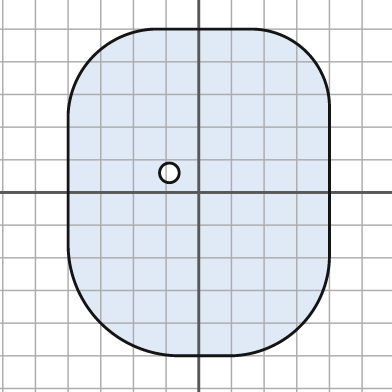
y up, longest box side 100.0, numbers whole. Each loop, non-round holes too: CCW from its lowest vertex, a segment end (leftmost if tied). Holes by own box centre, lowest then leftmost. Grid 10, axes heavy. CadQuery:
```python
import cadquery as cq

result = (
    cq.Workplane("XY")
    .moveTo(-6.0, -50.0)
    .lineTo(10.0, -50.0)
    .threePointArc((31.0, -41.0), (40.0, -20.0))
    .lineTo(40.0, 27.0)
    .threePointArc((33.0, 43.0), (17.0, 50.0))
    .lineTo(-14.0, 50.0)
    .threePointArc((-32.0, 42.0), (-40.0, 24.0))
    .lineTo(-40.0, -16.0)
    .threePointArc((-30.0, -40.0), (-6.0, -50.0))
    .close()
    .moveTo(-9.0, 6.0)
    .circle(3.0)
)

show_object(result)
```